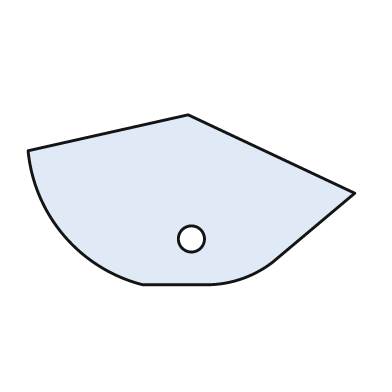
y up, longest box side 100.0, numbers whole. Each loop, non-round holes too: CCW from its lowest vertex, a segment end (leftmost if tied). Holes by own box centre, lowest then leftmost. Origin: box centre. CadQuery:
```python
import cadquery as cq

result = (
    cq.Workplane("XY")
    .moveTo(-15.0, -26.0)
    .lineTo(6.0, -26.0)
    .threePointArc((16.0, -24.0), (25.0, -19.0))
    .lineTo(50.0, 2.0)
    .lineTo(-1.0, 26.0)
    .lineTo(-50.0, 15.0)
    .threePointArc((-39.0, -11.0), (-15.0, -26.0))
    .close()
    .moveTo(0.0, -12.0)
    .circle(4.0)
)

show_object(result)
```